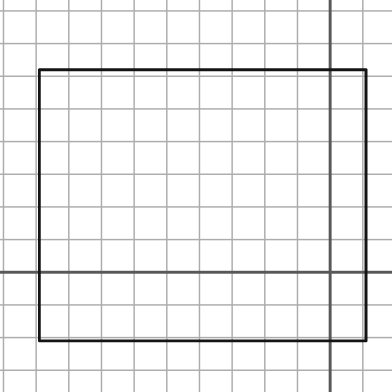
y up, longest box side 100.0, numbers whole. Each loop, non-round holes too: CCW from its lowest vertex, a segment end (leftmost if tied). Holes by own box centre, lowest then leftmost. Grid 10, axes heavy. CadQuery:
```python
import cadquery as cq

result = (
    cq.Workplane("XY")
    .moveTo(-89.0, -21.0)
    .lineTo(11.0, -21.0)
    .lineTo(11.0, 62.0)
    .lineTo(-89.0, 62.0)
    .close()
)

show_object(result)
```